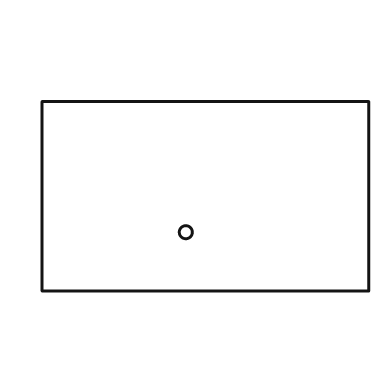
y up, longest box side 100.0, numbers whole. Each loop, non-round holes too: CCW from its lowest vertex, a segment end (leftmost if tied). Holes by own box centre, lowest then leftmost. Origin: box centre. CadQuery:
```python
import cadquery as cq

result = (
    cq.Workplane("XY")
    .moveTo(-50.0, -29.0)
    .lineTo(50.0, -29.0)
    .lineTo(50.0, 29.0)
    .lineTo(-50.0, 29.0)
    .close()
    .moveTo(-6.0, -11.0)
    .circle(2.0)
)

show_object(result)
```